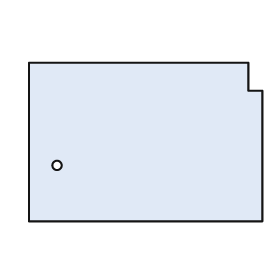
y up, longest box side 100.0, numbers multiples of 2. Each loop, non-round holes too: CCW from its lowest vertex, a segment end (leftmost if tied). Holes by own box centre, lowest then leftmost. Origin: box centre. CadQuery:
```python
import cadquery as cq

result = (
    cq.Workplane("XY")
    .moveTo(-50.0, -34.0)
    .lineTo(50.0, -34.0)
    .lineTo(50.0, 22.0)
    .lineTo(44.0, 22.0)
    .lineTo(44.0, 34.0)
    .lineTo(-50.0, 34.0)
    .close()
    .moveTo(-38.0, -10.0)
    .circle(2.0)
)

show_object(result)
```